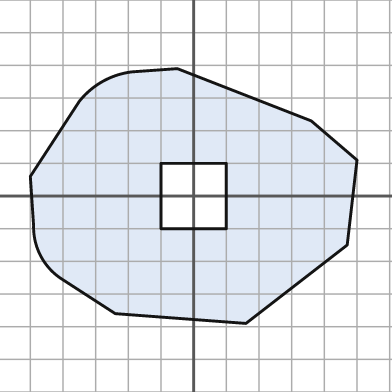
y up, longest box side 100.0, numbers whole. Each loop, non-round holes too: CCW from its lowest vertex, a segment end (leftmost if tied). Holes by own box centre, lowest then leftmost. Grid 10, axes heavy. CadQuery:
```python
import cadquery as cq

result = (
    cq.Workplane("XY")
    .moveTo(16.0, -39.0)
    .lineTo(47.0, -15.0)
    .lineTo(50.0, 11.0)
    .lineTo(36.0, 23.0)
    .lineTo(-5.0, 39.0)
    .lineTo(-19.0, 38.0)
    .threePointArc((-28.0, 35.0), (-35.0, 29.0))
    .lineTo(-50.0, 6.0)
    .lineTo(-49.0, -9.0)
    .threePointArc((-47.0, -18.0), (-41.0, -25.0))
    .lineTo(-24.0, -36.0)
    .close()
    .moveTo(-10.0, -10.0)
    .lineTo(10.0, -10.0)
    .lineTo(10.0, 10.0)
    .lineTo(-10.0, 10.0)
    .close()
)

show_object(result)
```